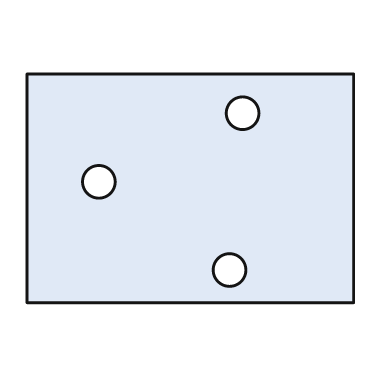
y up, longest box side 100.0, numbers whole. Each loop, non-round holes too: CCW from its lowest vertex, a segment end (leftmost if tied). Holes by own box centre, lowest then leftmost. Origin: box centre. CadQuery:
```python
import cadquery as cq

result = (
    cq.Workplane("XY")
    .moveTo(-50.0, -35.0)
    .lineTo(50.0, -35.0)
    .lineTo(50.0, 35.0)
    .lineTo(-50.0, 35.0)
    .close()
    .moveTo(12.0, -25.0)
    .circle(5.0)
    .moveTo(-28.0, 2.0)
    .circle(5.0)
    .moveTo(16.0, 23.0)
    .circle(5.0)
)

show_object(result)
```